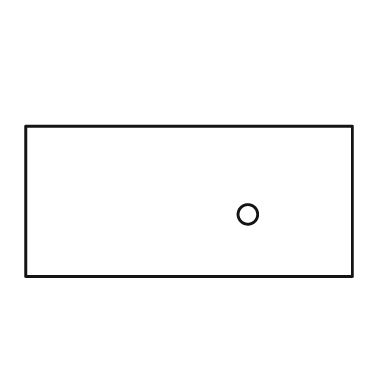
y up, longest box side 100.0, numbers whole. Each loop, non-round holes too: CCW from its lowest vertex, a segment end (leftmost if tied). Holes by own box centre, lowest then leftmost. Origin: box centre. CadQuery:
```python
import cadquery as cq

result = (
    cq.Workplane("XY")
    .moveTo(-50.0, -23.0)
    .lineTo(50.0, -23.0)
    .lineTo(50.0, 23.0)
    .lineTo(-50.0, 23.0)
    .close()
    .moveTo(18.0, -4.0)
    .circle(3.0)
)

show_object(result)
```